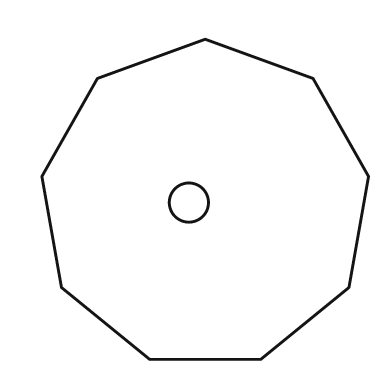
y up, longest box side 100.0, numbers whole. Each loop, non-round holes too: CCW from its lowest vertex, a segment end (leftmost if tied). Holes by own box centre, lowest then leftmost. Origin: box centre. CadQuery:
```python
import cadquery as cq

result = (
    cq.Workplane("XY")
    .moveTo(-17.0, -49.0)
    .lineTo(17.0, -49.0)
    .lineTo(44.0, -27.0)
    .lineTo(50.0, 7.0)
    .lineTo(33.0, 37.0)
    .lineTo(0.0, 49.0)
    .lineTo(-33.0, 37.0)
    .lineTo(-50.0, 7.0)
    .lineTo(-44.0, -27.0)
    .close()
    .moveTo(-5.0, -1.0)
    .circle(6.0)
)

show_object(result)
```